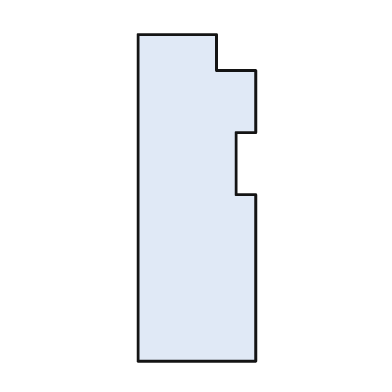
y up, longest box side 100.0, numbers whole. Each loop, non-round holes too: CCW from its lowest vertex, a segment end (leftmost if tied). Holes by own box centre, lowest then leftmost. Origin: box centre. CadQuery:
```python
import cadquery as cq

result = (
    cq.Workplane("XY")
    .moveTo(-18.0, -50.0)
    .lineTo(18.0, -50.0)
    .lineTo(18.0, 1.0)
    .lineTo(12.0, 1.0)
    .lineTo(12.0, 20.0)
    .lineTo(18.0, 20.0)
    .lineTo(18.0, 39.0)
    .lineTo(6.0, 39.0)
    .lineTo(6.0, 50.0)
    .lineTo(-18.0, 50.0)
    .close()
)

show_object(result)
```